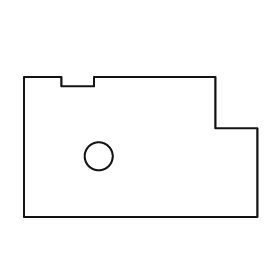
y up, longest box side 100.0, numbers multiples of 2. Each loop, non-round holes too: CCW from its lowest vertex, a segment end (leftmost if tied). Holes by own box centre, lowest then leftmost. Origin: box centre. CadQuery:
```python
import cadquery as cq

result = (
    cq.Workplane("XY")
    .moveTo(-50.0, -30.0)
    .lineTo(50.0, -30.0)
    .lineTo(50.0, 8.0)
    .lineTo(32.0, 8.0)
    .lineTo(32.0, 30.0)
    .lineTo(-20.0, 30.0)
    .lineTo(-20.0, 26.0)
    .lineTo(-34.0, 26.0)
    .lineTo(-34.0, 30.0)
    .lineTo(-50.0, 30.0)
    .close()
    .moveTo(-18.0, -4.0)
    .circle(6.0)
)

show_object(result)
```